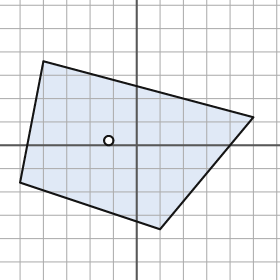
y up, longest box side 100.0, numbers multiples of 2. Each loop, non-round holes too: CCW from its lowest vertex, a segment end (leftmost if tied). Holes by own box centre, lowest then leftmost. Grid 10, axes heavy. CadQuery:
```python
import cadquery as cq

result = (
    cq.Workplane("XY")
    .moveTo(10.0, -36.0)
    .lineTo(50.0, 12.0)
    .lineTo(-40.0, 36.0)
    .lineTo(-50.0, -16.0)
    .close()
    .moveTo(-12.0, 2.0)
    .circle(2.0)
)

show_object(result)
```